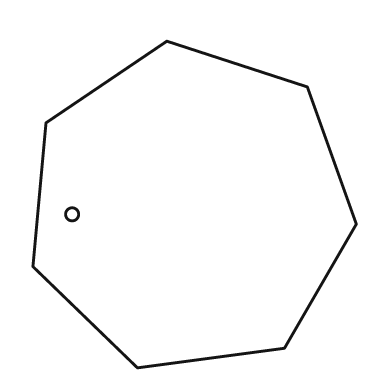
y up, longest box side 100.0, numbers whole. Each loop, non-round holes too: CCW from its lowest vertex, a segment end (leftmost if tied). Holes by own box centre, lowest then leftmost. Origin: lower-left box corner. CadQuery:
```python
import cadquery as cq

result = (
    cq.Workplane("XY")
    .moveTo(32.0, 0.0)
    .lineTo(77.0, 6.0)
    .lineTo(99.0, 44.0)
    .lineTo(84.0, 86.0)
    .lineTo(41.0, 100.0)
    .lineTo(4.0, 75.0)
    .lineTo(0.0, 31.0)
    .close()
    .moveTo(12.0, 47.0)
    .circle(2.0)
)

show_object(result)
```